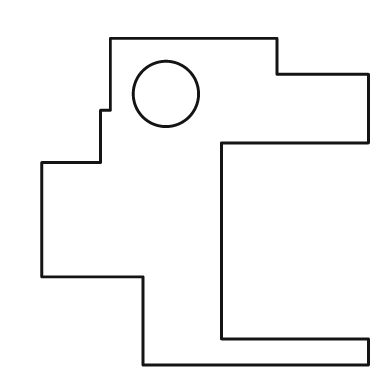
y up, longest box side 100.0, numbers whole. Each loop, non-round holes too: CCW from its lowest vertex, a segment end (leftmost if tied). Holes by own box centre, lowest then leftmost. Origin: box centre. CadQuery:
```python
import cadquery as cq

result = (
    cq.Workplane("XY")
    .moveTo(-19.0, -50.0)
    .lineTo(50.0, -50.0)
    .lineTo(50.0, -42.0)
    .lineTo(5.0, -42.0)
    .lineTo(5.0, 18.0)
    .lineTo(50.0, 18.0)
    .lineTo(50.0, 39.0)
    .lineTo(22.0, 39.0)
    .lineTo(22.0, 50.0)
    .lineTo(-29.0, 50.0)
    .lineTo(-29.0, 28.0)
    .lineTo(-32.0, 28.0)
    .lineTo(-32.0, 12.0)
    .lineTo(-50.0, 12.0)
    .lineTo(-50.0, -23.0)
    .lineTo(-19.0, -23.0)
    .close()
    .moveTo(-12.0, 33.0)
    .circle(10.0)
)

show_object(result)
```